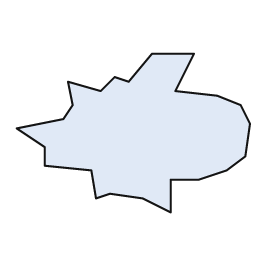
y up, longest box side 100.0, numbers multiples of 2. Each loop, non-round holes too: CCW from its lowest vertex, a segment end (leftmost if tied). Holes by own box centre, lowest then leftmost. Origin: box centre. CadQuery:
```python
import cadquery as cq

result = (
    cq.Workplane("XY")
    .moveTo(16.0, -34.0)
    .lineTo(16.0, -20.0)
    .lineTo(28.0, -20.0)
    .lineTo(40.0, -16.0)
    .lineTo(48.0, -10.0)
    .lineTo(50.0, 4.0)
    .lineTo(46.0, 12.0)
    .lineTo(36.0, 16.0)
    .lineTo(18.0, 18.0)
    .lineTo(26.0, 34.0)
    .lineTo(8.0, 34.0)
    .lineTo(-2.0, 22.0)
    .lineTo(-8.0, 24.0)
    .lineTo(-14.0, 18.0)
    .lineTo(-28.0, 22.0)
    .lineTo(-26.0, 12.0)
    .lineTo(-30.0, 6.0)
    .lineTo(-50.0, 2.0)
    .lineTo(-38.0, -6.0)
    .lineTo(-38.0, -14.0)
    .lineTo(-18.0, -16.0)
    .lineTo(-16.0, -28.0)
    .lineTo(-10.0, -26.0)
    .lineTo(4.0, -28.0)
    .close()
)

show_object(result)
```